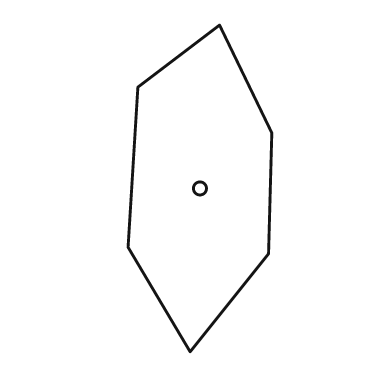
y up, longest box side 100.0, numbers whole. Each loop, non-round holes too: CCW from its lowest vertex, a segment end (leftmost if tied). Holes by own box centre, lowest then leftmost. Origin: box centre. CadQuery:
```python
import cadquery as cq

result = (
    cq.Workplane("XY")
    .moveTo(-3.0, -50.0)
    .lineTo(21.0, -20.0)
    .lineTo(22.0, 17.0)
    .lineTo(6.0, 50.0)
    .lineTo(-19.0, 31.0)
    .lineTo(-22.0, -18.0)
    .close()
    .moveTo(0.0, 0.0)
    .circle(2.0)
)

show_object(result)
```